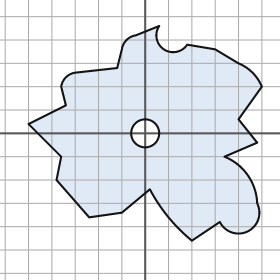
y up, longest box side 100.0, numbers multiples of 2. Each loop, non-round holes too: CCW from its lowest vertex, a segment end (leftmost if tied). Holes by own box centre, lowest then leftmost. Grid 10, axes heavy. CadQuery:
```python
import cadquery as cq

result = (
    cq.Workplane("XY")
    .moveTo(20.0, -46.0)
    .lineTo(32.0, -38.0)
    .threePointArc((44.0, -42.0), (48.0, -30.0))
    .threePointArc((44.0, -18.0), (34.0, -10.0))
    .lineTo(48.0, -4.0)
    .lineTo(40.0, 6.0)
    .lineTo(50.0, 20.0)
    .threePointArc((46.0, 26.0), (40.0, 30.0))
    .lineTo(30.0, 36.0)
    .lineTo(18.0, 38.0)
    .threePointArc((8.0, 36.0), (6.0, 46.0))
    .lineTo(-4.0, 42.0)
    .threePointArc((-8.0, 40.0), (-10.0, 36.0))
    .lineTo(-12.0, 28.0)
    .lineTo(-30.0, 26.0)
    .threePointArc((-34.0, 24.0), (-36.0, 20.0))
    .lineTo(-34.0, 12.0)
    .lineTo(-50.0, 4.0)
    .lineTo(-36.0, -10.0)
    .lineTo(-38.0, -20.0)
    .lineTo(-24.0, -36.0)
    .lineTo(-10.0, -34.0)
    .lineTo(2.0, -24.0)
    .threePointArc((10.0, -36.0), (20.0, -46.0))
    .close()
    .moveTo(0.0, 0.0)
    .circle(6.0)
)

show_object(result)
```